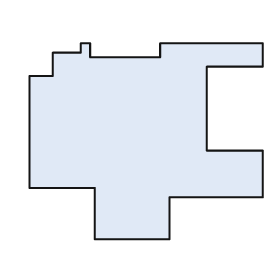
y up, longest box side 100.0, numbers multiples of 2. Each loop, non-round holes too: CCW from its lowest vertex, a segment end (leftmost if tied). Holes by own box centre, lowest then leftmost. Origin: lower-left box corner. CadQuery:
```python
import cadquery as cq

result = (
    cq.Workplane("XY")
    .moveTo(28.0, 0.0)
    .lineTo(60.0, 0.0)
    .lineTo(60.0, 18.0)
    .lineTo(100.0, 18.0)
    .lineTo(100.0, 38.0)
    .lineTo(76.0, 38.0)
    .lineTo(76.0, 74.0)
    .lineTo(100.0, 74.0)
    .lineTo(100.0, 84.0)
    .lineTo(56.0, 84.0)
    .lineTo(56.0, 78.0)
    .lineTo(26.0, 78.0)
    .lineTo(26.0, 84.0)
    .lineTo(22.0, 84.0)
    .lineTo(22.0, 80.0)
    .lineTo(10.0, 80.0)
    .lineTo(10.0, 70.0)
    .lineTo(0.0, 70.0)
    .lineTo(0.0, 22.0)
    .lineTo(28.0, 22.0)
    .close()
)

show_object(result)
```